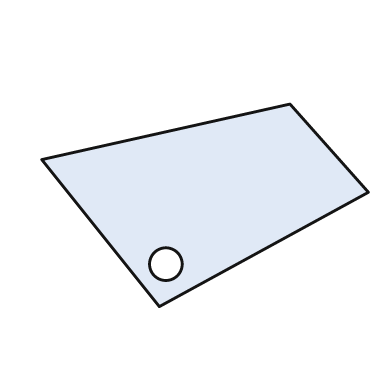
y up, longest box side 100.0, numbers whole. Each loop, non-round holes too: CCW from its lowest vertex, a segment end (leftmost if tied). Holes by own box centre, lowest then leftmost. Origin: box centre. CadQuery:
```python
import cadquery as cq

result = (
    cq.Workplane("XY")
    .moveTo(-14.0, -31.0)
    .lineTo(50.0, 4.0)
    .lineTo(26.0, 31.0)
    .lineTo(-50.0, 14.0)
    .close()
    .moveTo(-12.0, -18.0)
    .circle(5.0)
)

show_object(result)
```